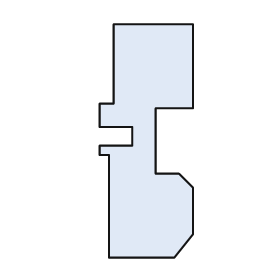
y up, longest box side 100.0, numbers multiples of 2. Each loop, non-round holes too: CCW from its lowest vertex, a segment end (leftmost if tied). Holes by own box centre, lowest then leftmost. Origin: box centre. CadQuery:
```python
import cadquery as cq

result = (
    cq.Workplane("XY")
    .moveTo(-16.0, -50.0)
    .lineTo(12.0, -50.0)
    .lineTo(20.0, -40.0)
    .lineTo(20.0, -20.0)
    .lineTo(14.0, -14.0)
    .lineTo(4.0, -14.0)
    .lineTo(4.0, 14.0)
    .lineTo(20.0, 14.0)
    .lineTo(20.0, 50.0)
    .lineTo(-14.0, 50.0)
    .lineTo(-14.0, 16.0)
    .lineTo(-20.0, 16.0)
    .lineTo(-20.0, 6.0)
    .lineTo(-6.0, 6.0)
    .lineTo(-6.0, -2.0)
    .lineTo(-20.0, -2.0)
    .lineTo(-20.0, -6.0)
    .lineTo(-16.0, -6.0)
    .close()
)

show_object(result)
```